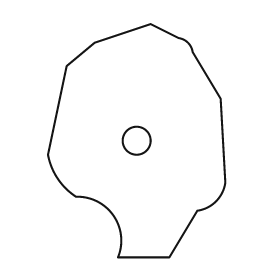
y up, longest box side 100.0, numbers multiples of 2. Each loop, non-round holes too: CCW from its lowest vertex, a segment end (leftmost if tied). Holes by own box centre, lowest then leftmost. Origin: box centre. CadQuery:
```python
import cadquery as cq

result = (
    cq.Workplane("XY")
    .moveTo(-8.0, -50.0)
    .lineTo(14.0, -50.0)
    .lineTo(26.0, -30.0)
    .threePointArc((34.0, -26.0), (38.0, -18.0))
    .lineTo(36.0, 18.0)
    .lineTo(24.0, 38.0)
    .threePointArc((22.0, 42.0), (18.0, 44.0))
    .lineTo(6.0, 50.0)
    .lineTo(-18.0, 42.0)
    .lineTo(-30.0, 32.0)
    .lineTo(-38.0, -6.0)
    .threePointArc((-34.0, -16.0), (-26.0, -24.0))
    .threePointArc((-10.0, -32.0), (-8.0, -50.0))
    .close()
    .moveTo(0.0, 0.0)
    .circle(6.0)
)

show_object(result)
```